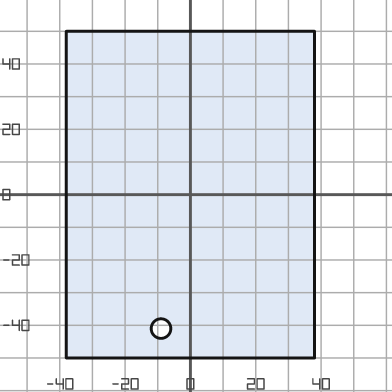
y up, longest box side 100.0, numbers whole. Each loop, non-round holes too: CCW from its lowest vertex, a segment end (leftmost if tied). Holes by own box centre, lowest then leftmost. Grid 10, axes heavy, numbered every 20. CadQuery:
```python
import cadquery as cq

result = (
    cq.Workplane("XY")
    .moveTo(-38.0, -50.0)
    .lineTo(38.0, -50.0)
    .lineTo(38.0, 50.0)
    .lineTo(-38.0, 50.0)
    .close()
    .moveTo(-9.0, -41.0)
    .circle(3.0)
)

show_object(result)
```